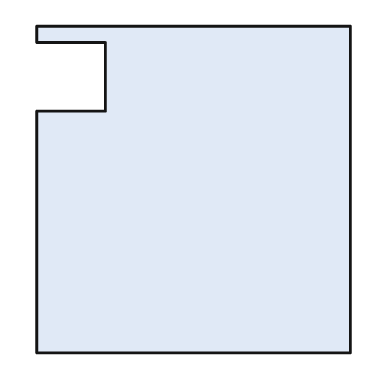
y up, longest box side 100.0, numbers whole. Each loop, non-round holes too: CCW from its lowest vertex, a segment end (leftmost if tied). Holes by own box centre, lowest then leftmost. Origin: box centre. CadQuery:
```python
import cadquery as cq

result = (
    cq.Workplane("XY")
    .moveTo(-48.0, -50.0)
    .lineTo(48.0, -50.0)
    .lineTo(48.0, 50.0)
    .lineTo(-48.0, 50.0)
    .lineTo(-48.0, 45.0)
    .lineTo(-27.0, 45.0)
    .lineTo(-27.0, 24.0)
    .lineTo(-48.0, 24.0)
    .close()
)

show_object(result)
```